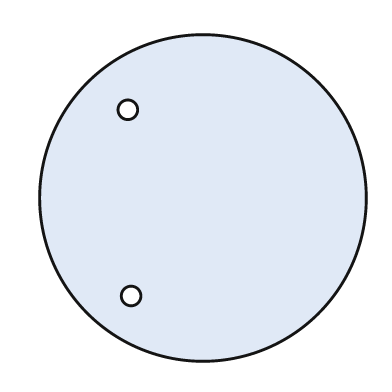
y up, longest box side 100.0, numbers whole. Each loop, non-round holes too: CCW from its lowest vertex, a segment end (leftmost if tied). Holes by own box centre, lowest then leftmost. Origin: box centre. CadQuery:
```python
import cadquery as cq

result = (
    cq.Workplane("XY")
    .moveTo(0.0, 0.0)
    .circle(50.0)
    .moveTo(-22.0, -30.0)
    .circle(3.0)
    .moveTo(-23.0, 27.0)
    .circle(3.0)
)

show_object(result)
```